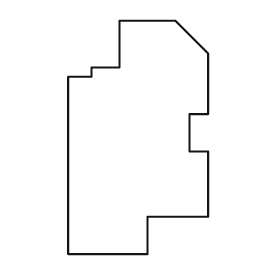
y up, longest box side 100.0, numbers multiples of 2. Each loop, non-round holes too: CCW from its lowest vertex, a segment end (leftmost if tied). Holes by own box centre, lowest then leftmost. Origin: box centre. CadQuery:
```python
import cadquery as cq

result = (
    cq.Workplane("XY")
    .moveTo(-30.0, -50.0)
    .lineTo(4.0, -50.0)
    .lineTo(4.0, -34.0)
    .lineTo(30.0, -34.0)
    .lineTo(30.0, -6.0)
    .lineTo(22.0, -6.0)
    .lineTo(22.0, 10.0)
    .lineTo(30.0, 10.0)
    .lineTo(30.0, 36.0)
    .lineTo(16.0, 50.0)
    .lineTo(-8.0, 50.0)
    .lineTo(-8.0, 30.0)
    .lineTo(-20.0, 30.0)
    .lineTo(-20.0, 26.0)
    .lineTo(-30.0, 26.0)
    .close()
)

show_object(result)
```